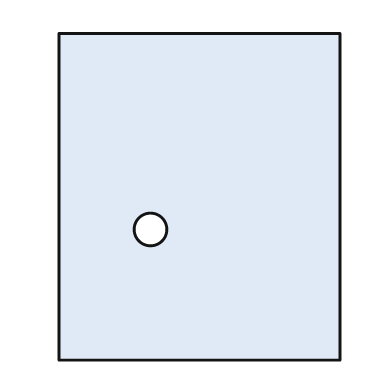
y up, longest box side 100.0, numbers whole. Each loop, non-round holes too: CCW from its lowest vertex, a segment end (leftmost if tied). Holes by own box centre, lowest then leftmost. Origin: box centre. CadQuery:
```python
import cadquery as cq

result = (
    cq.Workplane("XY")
    .moveTo(-43.0, -50.0)
    .lineTo(43.0, -50.0)
    .lineTo(43.0, 50.0)
    .lineTo(-43.0, 50.0)
    .close()
    .moveTo(-15.0, -10.0)
    .circle(5.0)
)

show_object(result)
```